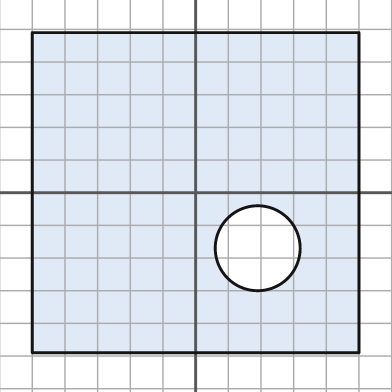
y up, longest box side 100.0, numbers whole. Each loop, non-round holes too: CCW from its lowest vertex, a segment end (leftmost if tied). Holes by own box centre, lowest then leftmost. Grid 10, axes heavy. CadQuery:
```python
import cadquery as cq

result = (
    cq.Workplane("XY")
    .moveTo(-50.0, -49.0)
    .lineTo(50.0, -49.0)
    .lineTo(50.0, 49.0)
    .lineTo(-50.0, 49.0)
    .close()
    .moveTo(19.0, -17.0)
    .circle(13.0)
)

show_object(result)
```